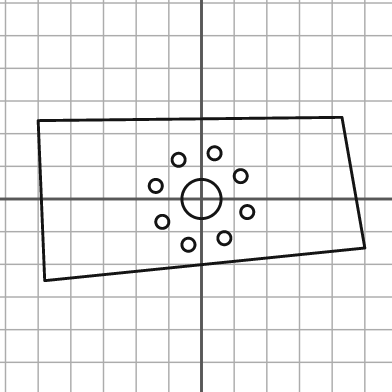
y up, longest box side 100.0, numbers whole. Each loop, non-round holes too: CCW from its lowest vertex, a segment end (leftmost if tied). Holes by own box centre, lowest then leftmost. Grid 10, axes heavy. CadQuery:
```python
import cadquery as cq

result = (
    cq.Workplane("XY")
    .moveTo(-48.0, -25.0)
    .lineTo(50.0, -15.0)
    .lineTo(43.0, 25.0)
    .lineTo(-50.0, 24.0)
    .close()
    .moveTo(-4.0, -14.0)
    .circle(2.0)
    .moveTo(7.0, -12.0)
    .circle(2.0)
    .moveTo(-12.0, -7.0)
    .circle(2.0)
    .moveTo(14.0, -4.0)
    .circle(2.0)
    .moveTo(0.0, 0.0)
    .circle(6.0)
    .moveTo(-14.0, 4.0)
    .circle(2.0)
    .moveTo(12.0, 7.0)
    .circle(2.0)
    .moveTo(-7.0, 12.0)
    .circle(2.0)
    .moveTo(4.0, 14.0)
    .circle(2.0)
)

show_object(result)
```